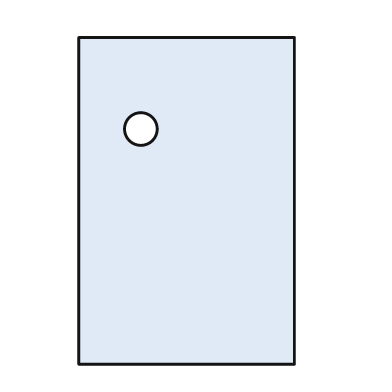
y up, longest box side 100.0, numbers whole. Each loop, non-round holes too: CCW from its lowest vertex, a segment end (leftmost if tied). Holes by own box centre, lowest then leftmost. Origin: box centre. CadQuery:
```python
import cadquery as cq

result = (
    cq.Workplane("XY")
    .moveTo(-33.0, -50.0)
    .lineTo(33.0, -50.0)
    .lineTo(33.0, 50.0)
    .lineTo(-33.0, 50.0)
    .close()
    .moveTo(-14.0, 22.0)
    .circle(5.0)
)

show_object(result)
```